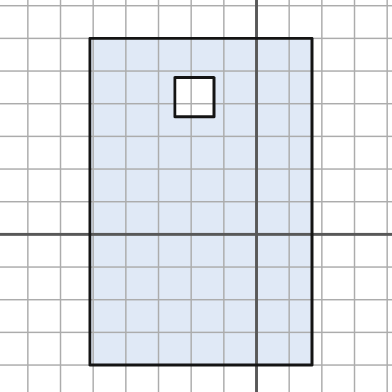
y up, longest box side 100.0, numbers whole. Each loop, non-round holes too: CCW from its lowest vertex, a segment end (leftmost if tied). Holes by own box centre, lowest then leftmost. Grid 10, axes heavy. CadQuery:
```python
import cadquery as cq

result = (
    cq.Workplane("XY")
    .moveTo(-51.0, -40.0)
    .lineTo(17.0, -40.0)
    .lineTo(17.0, 60.0)
    .lineTo(-51.0, 60.0)
    .close()
    .moveTo(-25.0, 36.0)
    .lineTo(-13.0, 36.0)
    .lineTo(-13.0, 48.0)
    .lineTo(-25.0, 48.0)
    .close()
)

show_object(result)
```